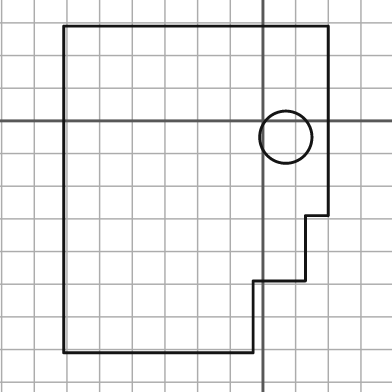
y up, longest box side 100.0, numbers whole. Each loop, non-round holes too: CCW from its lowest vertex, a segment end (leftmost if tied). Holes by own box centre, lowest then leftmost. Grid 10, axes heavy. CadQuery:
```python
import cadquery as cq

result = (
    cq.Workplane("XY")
    .moveTo(-61.0, -71.0)
    .lineTo(-3.0, -71.0)
    .lineTo(-3.0, -49.0)
    .lineTo(13.0, -49.0)
    .lineTo(13.0, -29.0)
    .lineTo(20.0, -29.0)
    .lineTo(20.0, 29.0)
    .lineTo(-61.0, 29.0)
    .close()
    .moveTo(7.0, -5.0)
    .circle(8.0)
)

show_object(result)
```